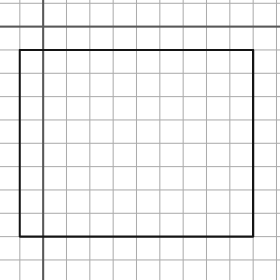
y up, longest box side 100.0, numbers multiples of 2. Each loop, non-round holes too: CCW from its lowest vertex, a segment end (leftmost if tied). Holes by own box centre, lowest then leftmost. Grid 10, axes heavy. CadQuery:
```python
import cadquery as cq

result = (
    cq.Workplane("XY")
    .moveTo(-10.0, -90.0)
    .lineTo(90.0, -90.0)
    .lineTo(90.0, -10.0)
    .lineTo(-10.0, -10.0)
    .close()
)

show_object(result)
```